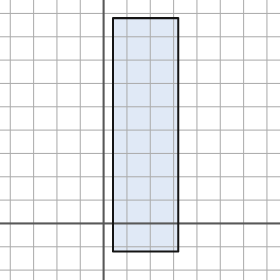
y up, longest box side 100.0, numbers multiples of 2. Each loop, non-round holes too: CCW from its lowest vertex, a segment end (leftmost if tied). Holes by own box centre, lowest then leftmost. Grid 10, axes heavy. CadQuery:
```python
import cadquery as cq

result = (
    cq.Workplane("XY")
    .moveTo(4.0, -12.0)
    .lineTo(32.0, -12.0)
    .lineTo(32.0, 88.0)
    .lineTo(4.0, 88.0)
    .close()
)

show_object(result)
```